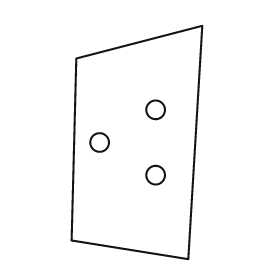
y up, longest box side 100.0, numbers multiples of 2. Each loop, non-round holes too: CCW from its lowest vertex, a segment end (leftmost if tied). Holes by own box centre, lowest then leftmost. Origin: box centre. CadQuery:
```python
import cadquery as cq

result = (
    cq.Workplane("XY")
    .moveTo(22.0, -50.0)
    .lineTo(28.0, 50.0)
    .lineTo(-26.0, 36.0)
    .lineTo(-28.0, -42.0)
    .close()
    .moveTo(8.0, -14.0)
    .circle(4.0)
    .moveTo(-16.0, 0.0)
    .circle(4.0)
    .moveTo(8.0, 14.0)
    .circle(4.0)
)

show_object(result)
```